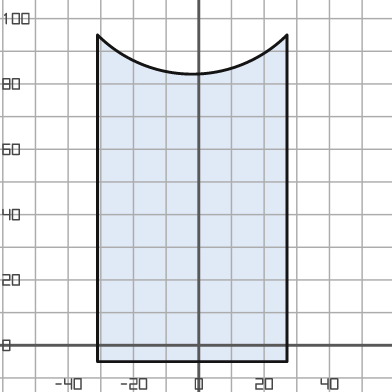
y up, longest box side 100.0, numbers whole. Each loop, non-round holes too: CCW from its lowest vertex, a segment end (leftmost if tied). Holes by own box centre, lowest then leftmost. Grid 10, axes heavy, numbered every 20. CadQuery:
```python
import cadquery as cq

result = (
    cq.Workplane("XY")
    .moveTo(-31.0, -5.0)
    .lineTo(27.0, -5.0)
    .lineTo(27.0, 95.0)
    .threePointArc((-2.0, 83.0), (-31.0, 95.0))
    .close()
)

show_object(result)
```